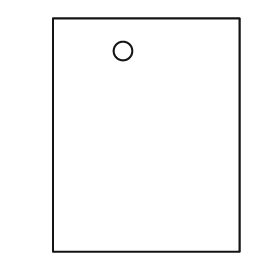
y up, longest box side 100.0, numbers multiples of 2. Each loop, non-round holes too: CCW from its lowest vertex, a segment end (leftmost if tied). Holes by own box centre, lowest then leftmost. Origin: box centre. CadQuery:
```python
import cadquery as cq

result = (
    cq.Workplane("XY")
    .moveTo(-40.0, -50.0)
    .lineTo(40.0, -50.0)
    .lineTo(40.0, 50.0)
    .lineTo(-40.0, 50.0)
    .close()
    .moveTo(-10.0, 36.0)
    .circle(4.0)
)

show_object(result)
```